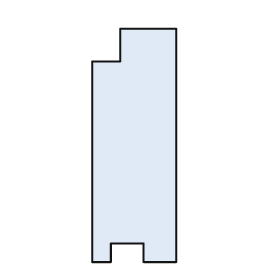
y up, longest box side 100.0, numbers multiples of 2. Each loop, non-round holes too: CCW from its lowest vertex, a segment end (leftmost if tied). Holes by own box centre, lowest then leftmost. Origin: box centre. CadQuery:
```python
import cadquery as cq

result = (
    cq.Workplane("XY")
    .moveTo(-18.0, -50.0)
    .lineTo(-10.0, -50.0)
    .lineTo(-10.0, -42.0)
    .lineTo(4.0, -42.0)
    .lineTo(4.0, -50.0)
    .lineTo(18.0, -50.0)
    .lineTo(18.0, 50.0)
    .lineTo(-6.0, 50.0)
    .lineTo(-6.0, 36.0)
    .lineTo(-18.0, 36.0)
    .close()
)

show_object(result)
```